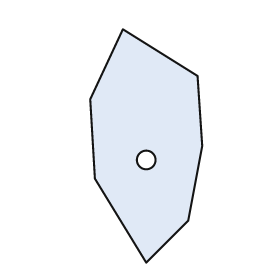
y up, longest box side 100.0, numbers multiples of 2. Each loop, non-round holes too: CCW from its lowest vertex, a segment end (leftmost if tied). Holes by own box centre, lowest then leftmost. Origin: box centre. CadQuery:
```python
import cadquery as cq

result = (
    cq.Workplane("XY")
    .moveTo(0.0, -50.0)
    .lineTo(18.0, -32.0)
    .lineTo(24.0, 0.0)
    .lineTo(22.0, 30.0)
    .lineTo(-10.0, 50.0)
    .lineTo(-24.0, 20.0)
    .lineTo(-22.0, -14.0)
    .close()
    .moveTo(0.0, -6.0)
    .circle(4.0)
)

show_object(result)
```